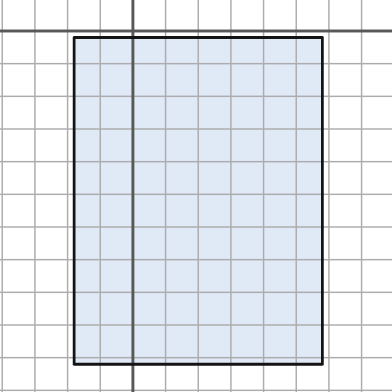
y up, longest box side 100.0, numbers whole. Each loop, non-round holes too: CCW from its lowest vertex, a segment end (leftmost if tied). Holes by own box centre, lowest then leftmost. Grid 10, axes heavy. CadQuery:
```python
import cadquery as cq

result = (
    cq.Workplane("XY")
    .moveTo(-18.0, -102.0)
    .lineTo(58.0, -102.0)
    .lineTo(58.0, -2.0)
    .lineTo(-18.0, -2.0)
    .close()
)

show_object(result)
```